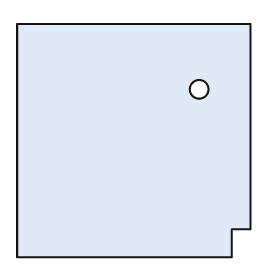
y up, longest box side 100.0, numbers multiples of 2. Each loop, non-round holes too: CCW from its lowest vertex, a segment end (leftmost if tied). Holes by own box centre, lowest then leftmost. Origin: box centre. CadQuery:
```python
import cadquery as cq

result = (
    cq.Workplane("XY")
    .moveTo(-50.0, -50.0)
    .lineTo(42.0, -50.0)
    .lineTo(42.0, -38.0)
    .lineTo(50.0, -38.0)
    .lineTo(50.0, 50.0)
    .lineTo(-50.0, 50.0)
    .close()
    .moveTo(28.0, 22.0)
    .circle(4.0)
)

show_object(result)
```